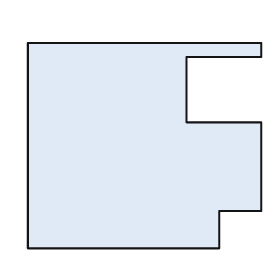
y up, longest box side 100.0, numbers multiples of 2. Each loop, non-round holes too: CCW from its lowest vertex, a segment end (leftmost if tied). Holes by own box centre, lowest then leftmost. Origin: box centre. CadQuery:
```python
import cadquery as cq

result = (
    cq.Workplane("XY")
    .moveTo(-50.0, -44.0)
    .lineTo(32.0, -44.0)
    .lineTo(32.0, -28.0)
    .lineTo(50.0, -28.0)
    .lineTo(50.0, 10.0)
    .lineTo(18.0, 10.0)
    .lineTo(18.0, 38.0)
    .lineTo(50.0, 38.0)
    .lineTo(50.0, 44.0)
    .lineTo(-50.0, 44.0)
    .close()
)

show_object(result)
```